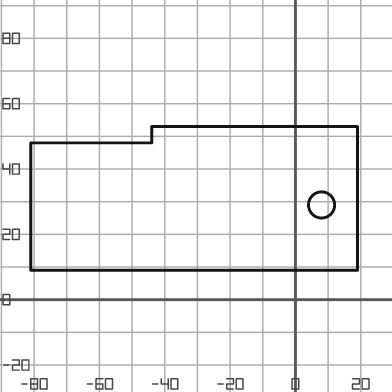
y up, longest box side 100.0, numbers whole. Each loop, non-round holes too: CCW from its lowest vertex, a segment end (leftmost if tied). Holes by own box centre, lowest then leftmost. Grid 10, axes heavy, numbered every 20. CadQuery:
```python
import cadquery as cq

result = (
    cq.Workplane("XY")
    .moveTo(-81.0, 9.0)
    .lineTo(19.0, 9.0)
    .lineTo(19.0, 53.0)
    .lineTo(-44.0, 53.0)
    .lineTo(-44.0, 48.0)
    .lineTo(-81.0, 48.0)
    .close()
    .moveTo(8.0, 29.0)
    .circle(4.0)
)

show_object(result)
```